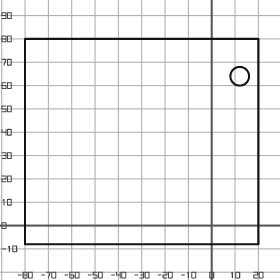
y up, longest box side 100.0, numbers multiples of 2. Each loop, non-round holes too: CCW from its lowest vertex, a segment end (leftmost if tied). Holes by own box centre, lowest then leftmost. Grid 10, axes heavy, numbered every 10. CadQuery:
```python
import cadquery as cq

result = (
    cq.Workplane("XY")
    .moveTo(-80.0, -8.0)
    .lineTo(20.0, -8.0)
    .lineTo(20.0, 80.0)
    .lineTo(-80.0, 80.0)
    .close()
    .moveTo(12.0, 64.0)
    .circle(4.0)
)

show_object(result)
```